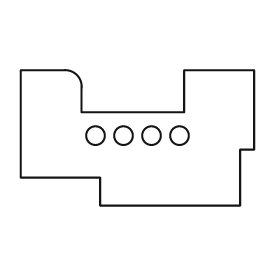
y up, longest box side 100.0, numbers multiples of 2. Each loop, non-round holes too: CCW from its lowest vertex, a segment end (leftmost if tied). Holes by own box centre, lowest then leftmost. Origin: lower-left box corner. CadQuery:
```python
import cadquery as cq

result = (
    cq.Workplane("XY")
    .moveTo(34.0, 0.0)
    .lineTo(94.0, 0.0)
    .lineTo(94.0, 24.0)
    .lineTo(100.0, 24.0)
    .lineTo(100.0, 58.0)
    .lineTo(70.0, 58.0)
    .lineTo(70.0, 40.0)
    .lineTo(26.0, 40.0)
    .lineTo(26.0, 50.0)
    .threePointArc((24.0, 56.0), (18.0, 58.0))
    .lineTo(0.0, 58.0)
    .lineTo(0.0, 12.0)
    .lineTo(34.0, 12.0)
    .close()
    .moveTo(32.0, 30.0)
    .circle(4.0)
    .moveTo(44.0, 30.0)
    .circle(4.0)
    .moveTo(56.0, 30.0)
    .circle(4.0)
    .moveTo(68.0, 30.0)
    .circle(4.0)
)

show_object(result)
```